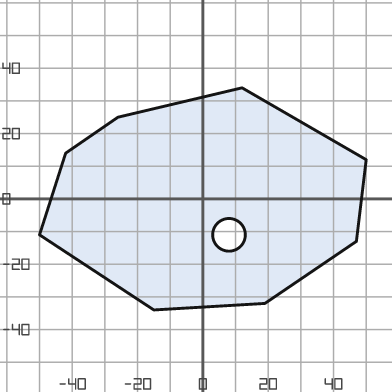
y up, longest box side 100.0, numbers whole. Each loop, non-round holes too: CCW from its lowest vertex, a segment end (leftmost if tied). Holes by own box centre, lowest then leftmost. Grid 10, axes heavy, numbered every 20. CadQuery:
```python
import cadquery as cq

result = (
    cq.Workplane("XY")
    .moveTo(-15.0, -34.0)
    .lineTo(19.0, -32.0)
    .lineTo(47.0, -13.0)
    .lineTo(50.0, 12.0)
    .lineTo(12.0, 34.0)
    .lineTo(-26.0, 25.0)
    .lineTo(-42.0, 14.0)
    .lineTo(-50.0, -11.0)
    .close()
    .moveTo(8.0, -11.0)
    .circle(5.0)
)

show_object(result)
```